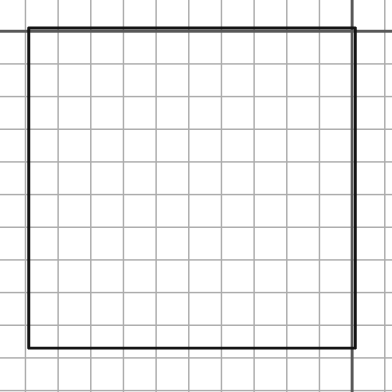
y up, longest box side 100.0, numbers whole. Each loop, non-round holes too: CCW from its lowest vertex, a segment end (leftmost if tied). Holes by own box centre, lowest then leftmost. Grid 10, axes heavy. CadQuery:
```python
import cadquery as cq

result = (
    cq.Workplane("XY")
    .moveTo(-99.0, -97.0)
    .lineTo(1.0, -97.0)
    .lineTo(1.0, 1.0)
    .lineTo(-99.0, 1.0)
    .close()
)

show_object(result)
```